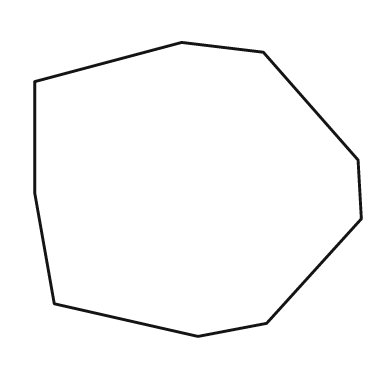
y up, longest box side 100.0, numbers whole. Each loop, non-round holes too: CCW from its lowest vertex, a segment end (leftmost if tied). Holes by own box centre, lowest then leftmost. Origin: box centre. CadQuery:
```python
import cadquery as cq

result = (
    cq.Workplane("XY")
    .moveTo(0.0, -45.0)
    .lineTo(21.0, -41.0)
    .lineTo(50.0, -9.0)
    .lineTo(49.0, 9.0)
    .lineTo(20.0, 42.0)
    .lineTo(-5.0, 45.0)
    .lineTo(-50.0, 33.0)
    .lineTo(-50.0, -1.0)
    .lineTo(-44.0, -35.0)
    .close()
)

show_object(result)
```